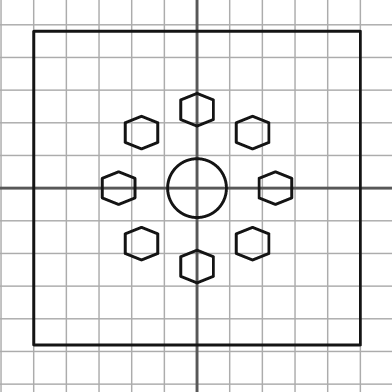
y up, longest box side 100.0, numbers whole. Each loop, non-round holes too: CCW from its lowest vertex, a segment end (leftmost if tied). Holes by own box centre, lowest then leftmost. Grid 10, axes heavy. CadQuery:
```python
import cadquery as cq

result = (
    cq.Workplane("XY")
    .moveTo(-50.0, -48.0)
    .lineTo(50.0, -48.0)
    .lineTo(50.0, 48.0)
    .lineTo(-50.0, 48.0)
    .close()
    .moveTo(0.0, -29.0)
    .lineTo(5.0, -27.0)
    .lineTo(5.0, -21.0)
    .lineTo(0.0, -19.0)
    .lineTo(-5.0, -21.0)
    .lineTo(-5.0, -27.0)
    .close()
    .moveTo(-17.0, -22.0)
    .lineTo(-12.0, -20.0)
    .lineTo(-12.0, -14.0)
    .lineTo(-17.0, -12.0)
    .lineTo(-22.0, -14.0)
    .lineTo(-22.0, -20.0)
    .close()
    .moveTo(17.0, -22.0)
    .lineTo(22.0, -20.0)
    .lineTo(22.0, -14.0)
    .lineTo(17.0, -12.0)
    .lineTo(12.0, -14.0)
    .lineTo(12.0, -20.0)
    .close()
    .moveTo(-24.0, -5.0)
    .lineTo(-19.0, -3.0)
    .lineTo(-19.0, 3.0)
    .lineTo(-24.0, 5.0)
    .lineTo(-29.0, 3.0)
    .lineTo(-29.0, -3.0)
    .close()
    .moveTo(0.0, 0.0)
    .circle(9.0)
    .moveTo(24.0, -5.0)
    .lineTo(29.0, -3.0)
    .lineTo(29.0, 3.0)
    .lineTo(24.0, 5.0)
    .lineTo(19.0, 3.0)
    .lineTo(19.0, -3.0)
    .close()
    .moveTo(-17.0, 12.0)
    .lineTo(-12.0, 14.0)
    .lineTo(-12.0, 20.0)
    .lineTo(-17.0, 22.0)
    .lineTo(-22.0, 20.0)
    .lineTo(-22.0, 14.0)
    .close()
    .moveTo(17.0, 12.0)
    .lineTo(22.0, 14.0)
    .lineTo(22.0, 20.0)
    .lineTo(17.0, 22.0)
    .lineTo(12.0, 20.0)
    .lineTo(12.0, 14.0)
    .close()
    .moveTo(0.0, 19.0)
    .lineTo(5.0, 21.0)
    .lineTo(5.0, 27.0)
    .lineTo(0.0, 29.0)
    .lineTo(-5.0, 27.0)
    .lineTo(-5.0, 21.0)
    .close()
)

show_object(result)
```